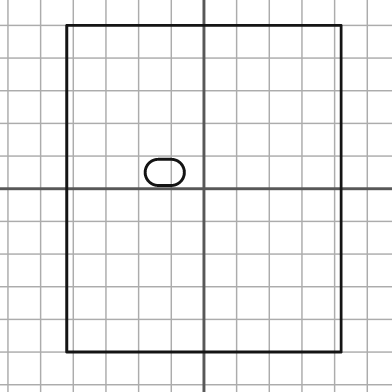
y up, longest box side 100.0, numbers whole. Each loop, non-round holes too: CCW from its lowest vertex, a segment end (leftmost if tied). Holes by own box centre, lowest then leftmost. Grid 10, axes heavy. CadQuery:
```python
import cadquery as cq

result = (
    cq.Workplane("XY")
    .moveTo(-42.0, -50.0)
    .lineTo(42.0, -50.0)
    .lineTo(42.0, 50.0)
    .lineTo(-42.0, 50.0)
    .close()
    .moveTo(-14.0, 1.0)
    .lineTo(-10.0, 1.0)
    .threePointArc((-6.0, 5.0), (-10.0, 9.0))
    .lineTo(-14.0, 9.0)
    .threePointArc((-18.0, 5.0), (-14.0, 1.0))
    .close()
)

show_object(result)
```